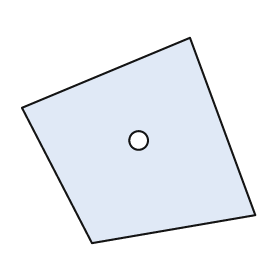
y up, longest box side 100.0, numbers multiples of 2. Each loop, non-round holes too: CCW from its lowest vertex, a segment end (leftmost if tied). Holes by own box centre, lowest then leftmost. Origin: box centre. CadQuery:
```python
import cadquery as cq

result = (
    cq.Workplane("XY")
    .moveTo(-20.0, -44.0)
    .lineTo(50.0, -32.0)
    .lineTo(22.0, 44.0)
    .lineTo(-50.0, 14.0)
    .close()
    .moveTo(0.0, 0.0)
    .circle(4.0)
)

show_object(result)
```